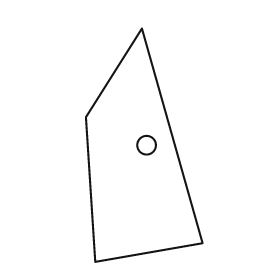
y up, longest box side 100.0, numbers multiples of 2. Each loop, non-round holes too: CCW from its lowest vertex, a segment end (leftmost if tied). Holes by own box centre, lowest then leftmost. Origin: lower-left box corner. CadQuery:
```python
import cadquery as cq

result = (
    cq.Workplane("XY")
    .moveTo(4.0, 0.0)
    .lineTo(50.0, 8.0)
    .lineTo(24.0, 100.0)
    .lineTo(0.0, 62.0)
    .close()
    .moveTo(26.0, 50.0)
    .circle(4.0)
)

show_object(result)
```